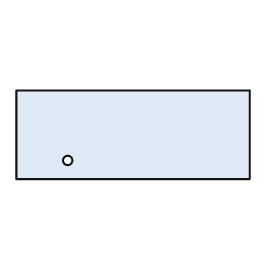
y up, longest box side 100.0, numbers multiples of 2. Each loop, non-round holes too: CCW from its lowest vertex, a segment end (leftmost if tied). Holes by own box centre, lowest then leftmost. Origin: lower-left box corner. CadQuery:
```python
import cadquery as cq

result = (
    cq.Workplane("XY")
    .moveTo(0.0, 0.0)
    .lineTo(100.0, 0.0)
    .lineTo(100.0, 38.0)
    .lineTo(0.0, 38.0)
    .close()
    .moveTo(22.0, 8.0)
    .circle(2.0)
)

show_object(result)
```